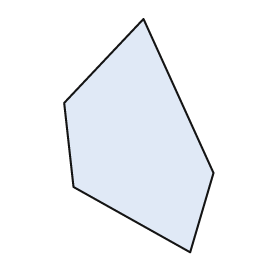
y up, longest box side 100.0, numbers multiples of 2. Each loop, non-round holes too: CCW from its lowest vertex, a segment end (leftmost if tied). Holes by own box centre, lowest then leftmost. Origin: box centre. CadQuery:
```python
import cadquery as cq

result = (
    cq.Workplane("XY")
    .moveTo(22.0, -50.0)
    .lineTo(32.0, -16.0)
    .lineTo(2.0, 50.0)
    .lineTo(-32.0, 14.0)
    .lineTo(-28.0, -22.0)
    .close()
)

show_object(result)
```